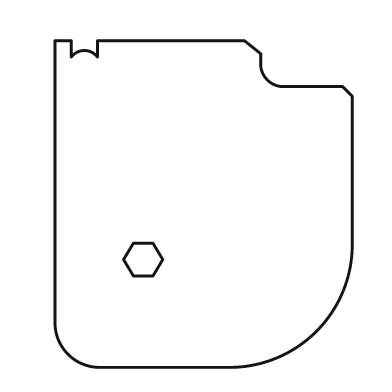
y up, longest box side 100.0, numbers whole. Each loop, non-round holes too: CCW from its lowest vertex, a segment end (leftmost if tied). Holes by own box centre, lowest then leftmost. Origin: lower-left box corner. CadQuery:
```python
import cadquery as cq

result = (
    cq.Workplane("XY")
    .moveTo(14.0, 0.0)
    .lineTo(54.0, 0.0)
    .threePointArc((80.0, 11.0), (91.0, 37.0))
    .lineTo(91.0, 83.0)
    .lineTo(88.0, 86.0)
    .lineTo(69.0, 86.0)
    .threePointArc((65.0, 88.0), (63.0, 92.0))
    .lineTo(63.0, 96.0)
    .lineTo(58.0, 100.0)
    .lineTo(13.0, 100.0)
    .lineTo(13.0, 95.0)
    .threePointArc((9.0, 97.0), (5.0, 95.0))
    .lineTo(5.0, 100.0)
    .lineTo(0.0, 100.0)
    .lineTo(0.0, 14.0)
    .threePointArc((4.0, 4.0), (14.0, 0.0))
    .close()
    .moveTo(24.0, 28.0)
    .lineTo(30.0, 28.0)
    .lineTo(33.0, 33.0)
    .lineTo(30.0, 38.0)
    .lineTo(24.0, 38.0)
    .lineTo(21.0, 33.0)
    .close()
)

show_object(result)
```